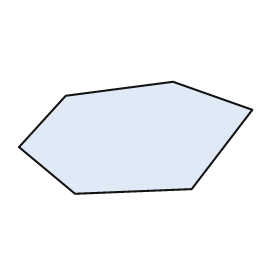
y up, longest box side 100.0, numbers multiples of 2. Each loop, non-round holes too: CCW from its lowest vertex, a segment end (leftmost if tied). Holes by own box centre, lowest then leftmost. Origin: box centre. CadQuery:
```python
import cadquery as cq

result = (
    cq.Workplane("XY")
    .moveTo(-26.0, -24.0)
    .lineTo(24.0, -22.0)
    .lineTo(50.0, 12.0)
    .lineTo(16.0, 24.0)
    .lineTo(-30.0, 18.0)
    .lineTo(-50.0, -4.0)
    .close()
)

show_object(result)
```